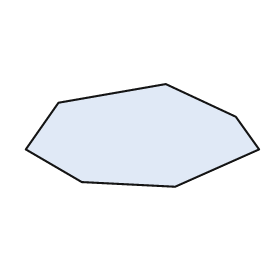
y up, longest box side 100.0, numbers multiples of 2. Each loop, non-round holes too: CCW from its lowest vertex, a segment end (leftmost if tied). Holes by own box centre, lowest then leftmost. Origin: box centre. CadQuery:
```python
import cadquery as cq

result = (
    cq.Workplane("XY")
    .moveTo(14.0, -22.0)
    .lineTo(50.0, -6.0)
    .lineTo(40.0, 8.0)
    .lineTo(10.0, 22.0)
    .lineTo(-36.0, 14.0)
    .lineTo(-50.0, -6.0)
    .lineTo(-26.0, -20.0)
    .close()
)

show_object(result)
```